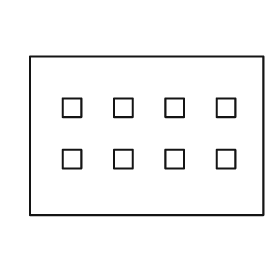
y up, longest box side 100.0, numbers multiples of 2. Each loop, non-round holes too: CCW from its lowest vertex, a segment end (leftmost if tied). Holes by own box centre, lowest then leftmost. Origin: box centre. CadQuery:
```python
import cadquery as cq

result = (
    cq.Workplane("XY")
    .moveTo(-50.0, -34.0)
    .lineTo(50.0, -34.0)
    .lineTo(50.0, 34.0)
    .lineTo(-50.0, 34.0)
    .close()
    .moveTo(-36.0, -14.0)
    .lineTo(-28.0, -14.0)
    .lineTo(-28.0, -6.0)
    .lineTo(-36.0, -6.0)
    .close()
    .moveTo(-14.0, -14.0)
    .lineTo(-6.0, -14.0)
    .lineTo(-6.0, -6.0)
    .lineTo(-14.0, -6.0)
    .close()
    .moveTo(8.0, -14.0)
    .lineTo(16.0, -14.0)
    .lineTo(16.0, -6.0)
    .lineTo(8.0, -6.0)
    .close()
    .moveTo(30.0, -14.0)
    .lineTo(38.0, -14.0)
    .lineTo(38.0, -6.0)
    .lineTo(30.0, -6.0)
    .close()
    .moveTo(-36.0, 8.0)
    .lineTo(-28.0, 8.0)
    .lineTo(-28.0, 16.0)
    .lineTo(-36.0, 16.0)
    .close()
    .moveTo(-14.0, 8.0)
    .lineTo(-6.0, 8.0)
    .lineTo(-6.0, 16.0)
    .lineTo(-14.0, 16.0)
    .close()
    .moveTo(8.0, 8.0)
    .lineTo(16.0, 8.0)
    .lineTo(16.0, 16.0)
    .lineTo(8.0, 16.0)
    .close()
    .moveTo(30.0, 8.0)
    .lineTo(38.0, 8.0)
    .lineTo(38.0, 16.0)
    .lineTo(30.0, 16.0)
    .close()
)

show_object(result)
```